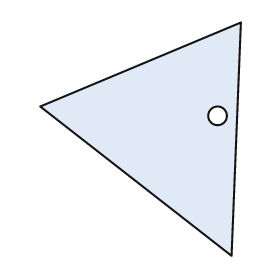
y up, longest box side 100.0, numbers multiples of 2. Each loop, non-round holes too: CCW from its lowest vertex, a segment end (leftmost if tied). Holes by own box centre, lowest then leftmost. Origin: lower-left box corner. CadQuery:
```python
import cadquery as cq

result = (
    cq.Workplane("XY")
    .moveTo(82.0, 0.0)
    .lineTo(86.0, 100.0)
    .lineTo(0.0, 64.0)
    .close()
    .moveTo(76.0, 60.0)
    .circle(4.0)
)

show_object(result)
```